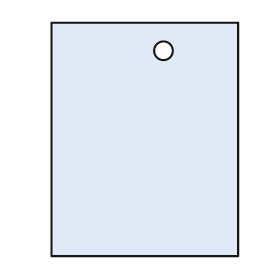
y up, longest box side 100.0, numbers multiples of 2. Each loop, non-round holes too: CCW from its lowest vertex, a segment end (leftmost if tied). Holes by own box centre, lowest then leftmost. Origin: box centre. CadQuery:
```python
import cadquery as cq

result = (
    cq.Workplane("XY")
    .moveTo(-40.0, -50.0)
    .lineTo(40.0, -50.0)
    .lineTo(40.0, 50.0)
    .lineTo(-40.0, 50.0)
    .close()
    .moveTo(8.0, 38.0)
    .circle(4.0)
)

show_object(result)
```